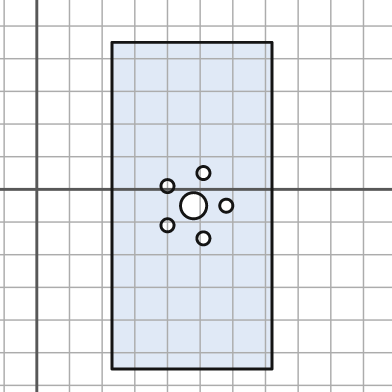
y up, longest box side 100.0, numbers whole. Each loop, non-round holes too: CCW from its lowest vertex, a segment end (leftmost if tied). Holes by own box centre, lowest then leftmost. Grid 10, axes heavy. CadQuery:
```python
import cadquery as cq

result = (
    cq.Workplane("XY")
    .moveTo(23.0, -55.0)
    .lineTo(72.0, -55.0)
    .lineTo(72.0, 45.0)
    .lineTo(23.0, 45.0)
    .close()
    .moveTo(51.0, -15.0)
    .circle(2.0)
    .moveTo(40.0, -11.0)
    .circle(2.0)
    .moveTo(48.0, -5.0)
    .circle(4.0)
    .moveTo(58.0, -5.0)
    .circle(2.0)
    .moveTo(40.0, 1.0)
    .circle(2.0)
    .moveTo(51.0, 5.0)
    .circle(2.0)
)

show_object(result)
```